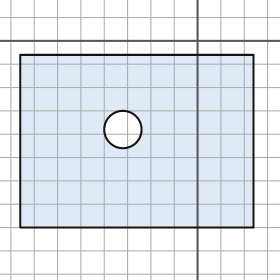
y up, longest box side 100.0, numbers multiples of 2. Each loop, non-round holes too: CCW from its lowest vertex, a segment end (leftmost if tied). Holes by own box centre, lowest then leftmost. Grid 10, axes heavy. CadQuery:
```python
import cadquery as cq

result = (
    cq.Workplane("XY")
    .moveTo(-76.0, -80.0)
    .lineTo(24.0, -80.0)
    .lineTo(24.0, -6.0)
    .lineTo(-76.0, -6.0)
    .close()
    .moveTo(-32.0, -38.0)
    .circle(8.0)
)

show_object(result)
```